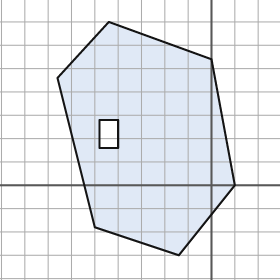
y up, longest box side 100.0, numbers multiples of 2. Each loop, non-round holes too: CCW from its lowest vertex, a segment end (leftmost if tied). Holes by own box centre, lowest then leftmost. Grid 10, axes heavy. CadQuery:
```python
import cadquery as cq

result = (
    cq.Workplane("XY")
    .moveTo(-14.0, -30.0)
    .lineTo(10.0, 0.0)
    .lineTo(0.0, 54.0)
    .lineTo(-44.0, 70.0)
    .lineTo(-66.0, 46.0)
    .lineTo(-50.0, -18.0)
    .close()
    .moveTo(-48.0, 16.0)
    .lineTo(-40.0, 16.0)
    .lineTo(-40.0, 28.0)
    .lineTo(-48.0, 28.0)
    .close()
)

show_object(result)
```